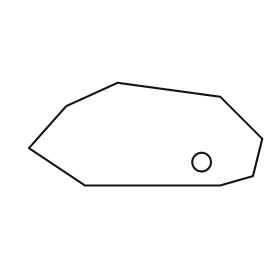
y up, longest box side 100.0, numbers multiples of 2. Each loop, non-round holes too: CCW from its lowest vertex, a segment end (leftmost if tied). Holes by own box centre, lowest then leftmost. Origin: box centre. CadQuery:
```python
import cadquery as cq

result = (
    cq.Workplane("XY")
    .moveTo(-26.0, -22.0)
    .lineTo(32.0, -22.0)
    .lineTo(46.0, -18.0)
    .lineTo(50.0, -2.0)
    .lineTo(32.0, 16.0)
    .lineTo(-12.0, 22.0)
    .lineTo(-34.0, 12.0)
    .lineTo(-50.0, -6.0)
    .close()
    .moveTo(24.0, -12.0)
    .circle(4.0)
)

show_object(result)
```